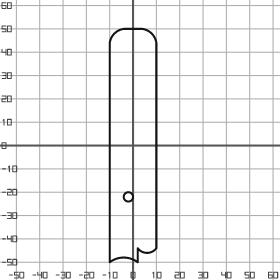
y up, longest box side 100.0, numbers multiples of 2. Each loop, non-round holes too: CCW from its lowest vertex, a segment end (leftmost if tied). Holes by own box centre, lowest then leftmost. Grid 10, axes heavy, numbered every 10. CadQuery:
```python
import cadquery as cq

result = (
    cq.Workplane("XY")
    .moveTo(-10.0, -50.0)
    .threePointArc((-4.0, -48.0), (2.0, -50.0))
    .lineTo(2.0, -44.0)
    .threePointArc((6.0, -46.0), (10.0, -44.0))
    .lineTo(10.0, 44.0)
    .threePointArc((8.0, 48.0), (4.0, 50.0))
    .lineTo(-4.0, 50.0)
    .threePointArc((-8.0, 48.0), (-10.0, 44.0))
    .close()
    .moveTo(-2.0, -22.0)
    .circle(2.0)
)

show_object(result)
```